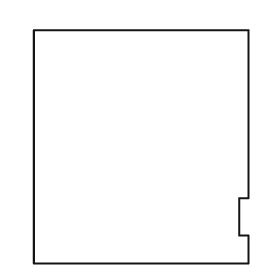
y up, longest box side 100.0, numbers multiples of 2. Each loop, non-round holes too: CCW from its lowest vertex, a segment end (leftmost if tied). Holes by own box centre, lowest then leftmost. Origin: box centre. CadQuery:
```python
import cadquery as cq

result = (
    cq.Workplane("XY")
    .moveTo(-46.0, -50.0)
    .lineTo(46.0, -50.0)
    .lineTo(46.0, -38.0)
    .lineTo(42.0, -38.0)
    .lineTo(42.0, -22.0)
    .lineTo(46.0, -22.0)
    .lineTo(46.0, 50.0)
    .lineTo(-46.0, 50.0)
    .close()
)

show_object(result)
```